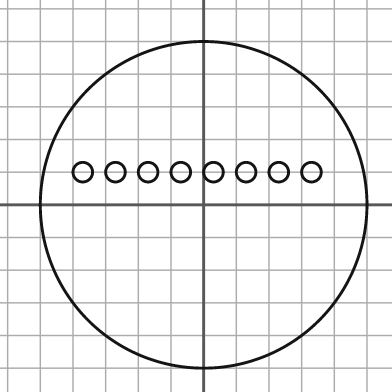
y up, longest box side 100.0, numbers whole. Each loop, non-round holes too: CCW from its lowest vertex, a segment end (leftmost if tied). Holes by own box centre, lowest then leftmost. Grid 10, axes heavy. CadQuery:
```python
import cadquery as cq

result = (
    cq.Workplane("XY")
    .moveTo(0.0, 0.0)
    .circle(50.0)
    .moveTo(-37.0, 10.0)
    .circle(3.0)
    .moveTo(-27.0, 10.0)
    .circle(3.0)
    .moveTo(-17.0, 10.0)
    .circle(3.0)
    .moveTo(-7.0, 10.0)
    .circle(3.0)
    .moveTo(3.0, 10.0)
    .circle(3.0)
    .moveTo(13.0, 10.0)
    .circle(3.0)
    .moveTo(23.0, 10.0)
    .circle(3.0)
    .moveTo(33.0, 10.0)
    .circle(3.0)
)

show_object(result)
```